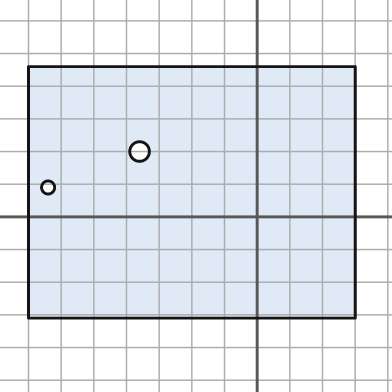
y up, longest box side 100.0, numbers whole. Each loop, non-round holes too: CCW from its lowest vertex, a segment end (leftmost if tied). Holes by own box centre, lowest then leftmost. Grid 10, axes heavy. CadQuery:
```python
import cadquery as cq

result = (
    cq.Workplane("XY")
    .moveTo(-70.0, -31.0)
    .lineTo(30.0, -31.0)
    .lineTo(30.0, 46.0)
    .lineTo(-70.0, 46.0)
    .close()
    .moveTo(-64.0, 9.0)
    .circle(2.0)
    .moveTo(-36.0, 20.0)
    .circle(3.0)
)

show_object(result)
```